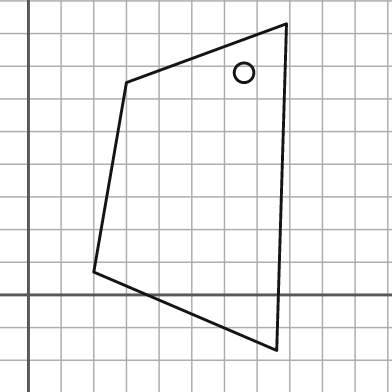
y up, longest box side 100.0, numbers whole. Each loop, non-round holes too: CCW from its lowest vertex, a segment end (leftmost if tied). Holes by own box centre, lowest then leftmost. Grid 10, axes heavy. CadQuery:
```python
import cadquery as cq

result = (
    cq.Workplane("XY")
    .moveTo(76.0, -17.0)
    .lineTo(79.0, 83.0)
    .lineTo(30.0, 65.0)
    .lineTo(20.0, 7.0)
    .close()
    .moveTo(66.0, 68.0)
    .circle(3.0)
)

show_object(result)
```